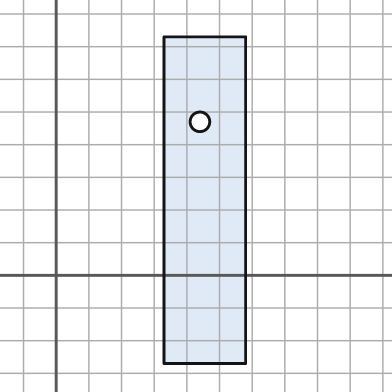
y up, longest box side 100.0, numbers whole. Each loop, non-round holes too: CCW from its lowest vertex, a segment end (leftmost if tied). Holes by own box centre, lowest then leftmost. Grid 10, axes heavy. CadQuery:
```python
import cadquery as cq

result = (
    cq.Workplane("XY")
    .moveTo(33.0, -27.0)
    .lineTo(58.0, -27.0)
    .lineTo(58.0, 73.0)
    .lineTo(33.0, 73.0)
    .close()
    .moveTo(44.0, 47.0)
    .circle(3.0)
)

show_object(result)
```